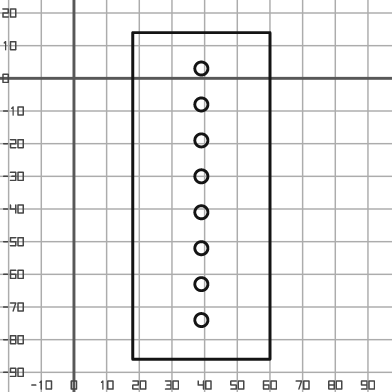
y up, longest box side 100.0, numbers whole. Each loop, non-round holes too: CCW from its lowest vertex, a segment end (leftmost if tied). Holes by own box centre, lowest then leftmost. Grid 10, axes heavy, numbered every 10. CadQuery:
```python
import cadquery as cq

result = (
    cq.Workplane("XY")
    .moveTo(18.0, -86.0)
    .lineTo(60.0, -86.0)
    .lineTo(60.0, 14.0)
    .lineTo(18.0, 14.0)
    .close()
    .moveTo(39.0, -74.0)
    .circle(2.0)
    .moveTo(39.0, -63.0)
    .circle(2.0)
    .moveTo(39.0, -52.0)
    .circle(2.0)
    .moveTo(39.0, -41.0)
    .circle(2.0)
    .moveTo(39.0, -30.0)
    .circle(2.0)
    .moveTo(39.0, -19.0)
    .circle(2.0)
    .moveTo(39.0, -8.0)
    .circle(2.0)
    .moveTo(39.0, 3.0)
    .circle(2.0)
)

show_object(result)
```